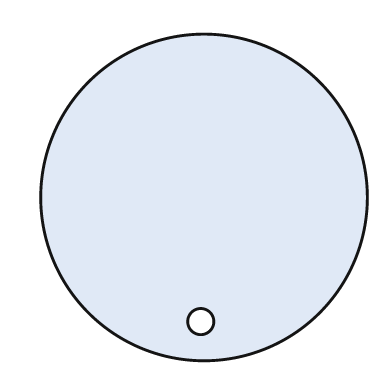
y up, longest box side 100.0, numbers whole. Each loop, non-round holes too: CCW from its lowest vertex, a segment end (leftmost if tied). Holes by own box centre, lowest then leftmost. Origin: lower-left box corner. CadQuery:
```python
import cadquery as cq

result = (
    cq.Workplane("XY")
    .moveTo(50.0, 50.0)
    .circle(50.0)
    .moveTo(49.0, 12.0)
    .circle(4.0)
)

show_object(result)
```